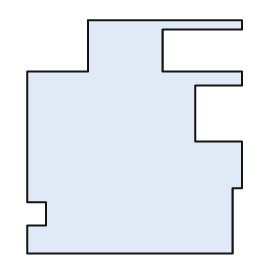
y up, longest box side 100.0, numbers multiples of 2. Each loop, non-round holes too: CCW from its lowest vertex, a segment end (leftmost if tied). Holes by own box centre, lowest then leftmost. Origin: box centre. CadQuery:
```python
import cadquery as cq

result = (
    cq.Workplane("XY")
    .moveTo(-46.0, -50.0)
    .lineTo(42.0, -50.0)
    .lineTo(42.0, -22.0)
    .lineTo(46.0, -22.0)
    .lineTo(46.0, -2.0)
    .lineTo(26.0, -2.0)
    .lineTo(26.0, 22.0)
    .lineTo(46.0, 22.0)
    .lineTo(46.0, 28.0)
    .lineTo(12.0, 28.0)
    .lineTo(12.0, 46.0)
    .lineTo(46.0, 46.0)
    .lineTo(46.0, 50.0)
    .lineTo(-20.0, 50.0)
    .lineTo(-20.0, 28.0)
    .lineTo(-46.0, 28.0)
    .lineTo(-46.0, -28.0)
    .lineTo(-38.0, -28.0)
    .lineTo(-38.0, -38.0)
    .lineTo(-46.0, -38.0)
    .close()
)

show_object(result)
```